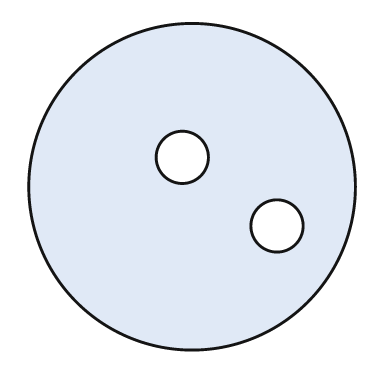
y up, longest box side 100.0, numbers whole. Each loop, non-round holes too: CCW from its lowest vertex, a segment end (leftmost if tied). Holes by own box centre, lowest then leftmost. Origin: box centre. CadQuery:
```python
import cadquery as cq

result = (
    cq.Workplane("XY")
    .moveTo(0.0, 0.0)
    .circle(50.0)
    .moveTo(26.0, -12.0)
    .circle(8.0)
    .moveTo(-3.0, 9.0)
    .circle(8.0)
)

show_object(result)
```